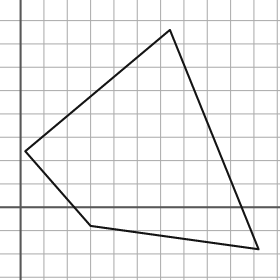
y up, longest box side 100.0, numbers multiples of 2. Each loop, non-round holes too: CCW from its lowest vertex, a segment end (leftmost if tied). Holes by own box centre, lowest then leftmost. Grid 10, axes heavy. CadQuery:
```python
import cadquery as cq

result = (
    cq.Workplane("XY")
    .moveTo(102.0, -18.0)
    .lineTo(64.0, 76.0)
    .lineTo(2.0, 24.0)
    .lineTo(30.0, -8.0)
    .close()
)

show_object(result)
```